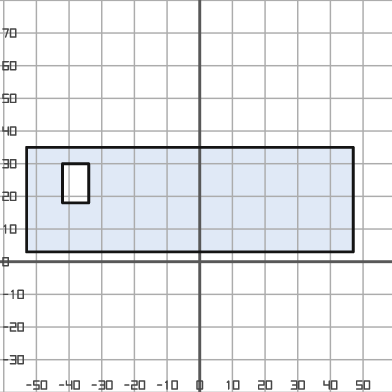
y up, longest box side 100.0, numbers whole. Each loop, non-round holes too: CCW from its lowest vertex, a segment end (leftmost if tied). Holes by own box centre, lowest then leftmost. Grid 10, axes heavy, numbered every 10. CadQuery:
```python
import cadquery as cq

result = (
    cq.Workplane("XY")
    .moveTo(-53.0, 3.0)
    .lineTo(47.0, 3.0)
    .lineTo(47.0, 35.0)
    .lineTo(-53.0, 35.0)
    .close()
    .moveTo(-42.0, 18.0)
    .lineTo(-34.0, 18.0)
    .lineTo(-34.0, 30.0)
    .lineTo(-42.0, 30.0)
    .close()
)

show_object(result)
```